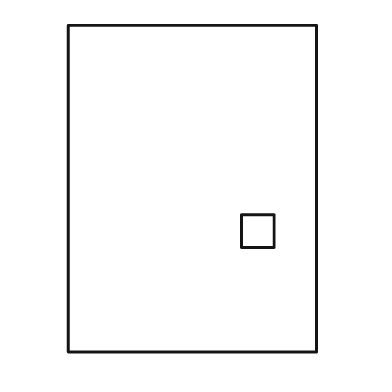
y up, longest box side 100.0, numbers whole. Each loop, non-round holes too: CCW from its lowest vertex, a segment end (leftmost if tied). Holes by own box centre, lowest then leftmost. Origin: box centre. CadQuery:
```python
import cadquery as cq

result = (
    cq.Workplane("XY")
    .moveTo(-38.0, -50.0)
    .lineTo(38.0, -50.0)
    .lineTo(38.0, 50.0)
    .lineTo(-38.0, 50.0)
    .close()
    .moveTo(15.0, -18.0)
    .lineTo(25.0, -18.0)
    .lineTo(25.0, -8.0)
    .lineTo(15.0, -8.0)
    .close()
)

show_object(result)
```